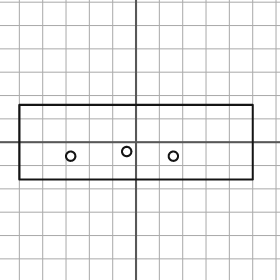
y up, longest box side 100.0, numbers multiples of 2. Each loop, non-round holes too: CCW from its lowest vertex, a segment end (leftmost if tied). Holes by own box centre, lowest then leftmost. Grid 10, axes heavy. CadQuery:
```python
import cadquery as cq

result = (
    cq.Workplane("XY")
    .moveTo(-50.0, -16.0)
    .lineTo(50.0, -16.0)
    .lineTo(50.0, 16.0)
    .lineTo(-50.0, 16.0)
    .close()
    .moveTo(-28.0, -6.0)
    .circle(2.0)
    .moveTo(16.0, -6.0)
    .circle(2.0)
    .moveTo(-4.0, -4.0)
    .circle(2.0)
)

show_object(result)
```